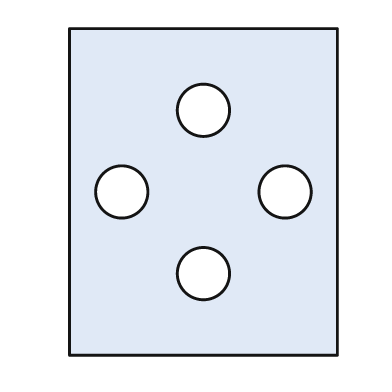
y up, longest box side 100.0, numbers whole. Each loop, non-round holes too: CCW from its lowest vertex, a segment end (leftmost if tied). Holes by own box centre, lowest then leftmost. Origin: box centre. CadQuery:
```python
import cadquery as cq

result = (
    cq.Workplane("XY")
    .moveTo(-41.0, -50.0)
    .lineTo(41.0, -50.0)
    .lineTo(41.0, 50.0)
    .lineTo(-41.0, 50.0)
    .close()
    .moveTo(0.0, -25.0)
    .circle(8.0)
    .moveTo(-25.0, 0.0)
    .circle(8.0)
    .moveTo(25.0, 0.0)
    .circle(8.0)
    .moveTo(0.0, 25.0)
    .circle(8.0)
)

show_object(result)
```